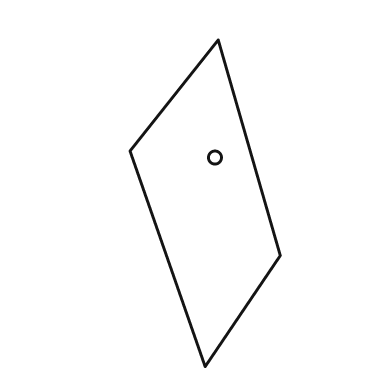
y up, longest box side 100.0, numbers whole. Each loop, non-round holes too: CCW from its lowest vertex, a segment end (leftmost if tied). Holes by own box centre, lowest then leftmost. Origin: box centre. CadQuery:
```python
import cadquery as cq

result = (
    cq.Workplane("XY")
    .moveTo(0.0, -50.0)
    .lineTo(23.0, -16.0)
    .lineTo(4.0, 50.0)
    .lineTo(-23.0, 16.0)
    .close()
    .moveTo(3.0, 14.0)
    .circle(2.0)
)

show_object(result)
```